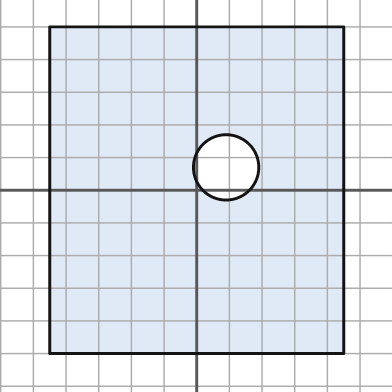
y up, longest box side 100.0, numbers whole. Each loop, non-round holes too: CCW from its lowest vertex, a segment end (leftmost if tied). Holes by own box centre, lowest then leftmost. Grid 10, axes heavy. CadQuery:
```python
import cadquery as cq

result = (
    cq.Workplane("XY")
    .moveTo(-45.0, -50.0)
    .lineTo(45.0, -50.0)
    .lineTo(45.0, 50.0)
    .lineTo(-45.0, 50.0)
    .close()
    .moveTo(9.0, 7.0)
    .circle(10.0)
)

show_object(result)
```